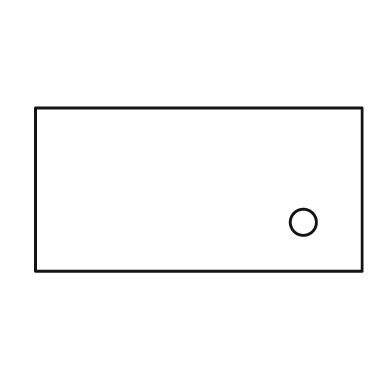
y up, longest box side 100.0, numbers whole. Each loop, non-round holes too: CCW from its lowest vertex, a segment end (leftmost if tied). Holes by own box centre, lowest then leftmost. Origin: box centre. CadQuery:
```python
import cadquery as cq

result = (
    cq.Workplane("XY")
    .moveTo(-50.0, -25.0)
    .lineTo(50.0, -25.0)
    .lineTo(50.0, 25.0)
    .lineTo(-50.0, 25.0)
    .close()
    .moveTo(32.0, -10.0)
    .circle(4.0)
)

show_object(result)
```